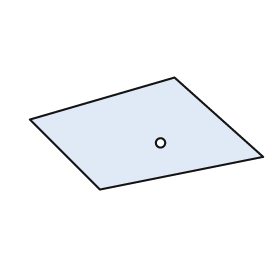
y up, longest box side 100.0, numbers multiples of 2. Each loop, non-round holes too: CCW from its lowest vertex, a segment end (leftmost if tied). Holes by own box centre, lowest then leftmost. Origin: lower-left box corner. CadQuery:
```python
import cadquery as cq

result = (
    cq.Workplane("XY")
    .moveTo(30.0, 0.0)
    .lineTo(100.0, 14.0)
    .lineTo(62.0, 48.0)
    .lineTo(0.0, 30.0)
    .close()
    .moveTo(56.0, 20.0)
    .circle(2.0)
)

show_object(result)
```